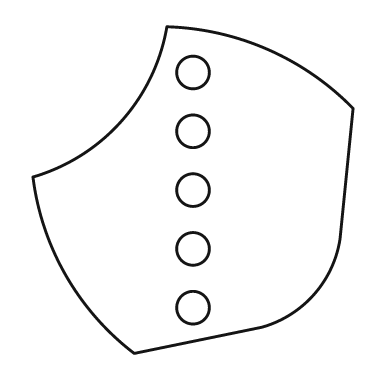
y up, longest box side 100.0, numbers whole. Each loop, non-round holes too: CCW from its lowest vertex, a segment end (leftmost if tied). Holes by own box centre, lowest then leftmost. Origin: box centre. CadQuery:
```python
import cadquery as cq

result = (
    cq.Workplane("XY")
    .moveTo(-18.0, -50.0)
    .lineTo(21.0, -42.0)
    .threePointArc((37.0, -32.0), (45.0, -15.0))
    .lineTo(49.0, 25.0)
    .threePointArc((23.0, 43.0), (-8.0, 50.0))
    .threePointArc((-22.0, 21.0), (-49.0, 4.0))
    .threePointArc((-39.0, -26.0), (-18.0, -50.0))
    .close()
    .moveTo(0.0, -36.0)
    .circle(5.0)
    .moveTo(0.0, -18.0)
    .circle(5.0)
    .moveTo(0.0, 0.0)
    .circle(5.0)
    .moveTo(0.0, 18.0)
    .circle(5.0)
    .moveTo(0.0, 36.0)
    .circle(5.0)
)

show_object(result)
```